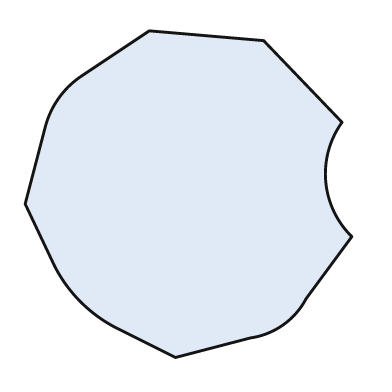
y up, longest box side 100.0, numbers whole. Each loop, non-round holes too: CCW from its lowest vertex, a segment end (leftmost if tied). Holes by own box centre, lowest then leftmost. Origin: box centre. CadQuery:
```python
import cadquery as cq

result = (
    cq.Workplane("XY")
    .moveTo(-4.0, -50.0)
    .lineTo(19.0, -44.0)
    .threePointArc((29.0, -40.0), (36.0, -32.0))
    .lineTo(50.0, -13.0)
    .threePointArc((42.0, 4.0), (47.0, 22.0))
    .lineTo(23.0, 47.0)
    .lineTo(-12.0, 50.0)
    .lineTo(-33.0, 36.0)
    .threePointArc((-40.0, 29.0), (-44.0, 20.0))
    .lineTo(-50.0, -3.0)
    .lineTo(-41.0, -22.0)
    .threePointArc((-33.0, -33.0), (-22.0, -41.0))
    .close()
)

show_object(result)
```